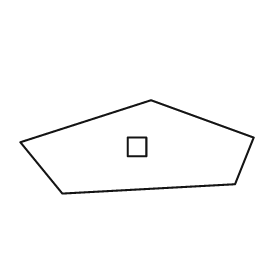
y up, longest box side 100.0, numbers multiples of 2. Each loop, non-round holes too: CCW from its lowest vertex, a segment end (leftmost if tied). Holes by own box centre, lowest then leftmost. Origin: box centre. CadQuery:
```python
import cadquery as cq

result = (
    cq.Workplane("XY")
    .moveTo(-32.0, -20.0)
    .lineTo(42.0, -16.0)
    .lineTo(50.0, 4.0)
    .lineTo(6.0, 20.0)
    .lineTo(-50.0, 2.0)
    .close()
    .moveTo(-4.0, -4.0)
    .lineTo(4.0, -4.0)
    .lineTo(4.0, 4.0)
    .lineTo(-4.0, 4.0)
    .close()
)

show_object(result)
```